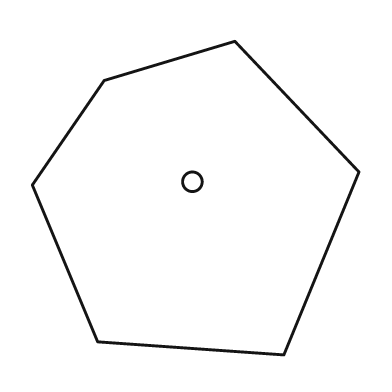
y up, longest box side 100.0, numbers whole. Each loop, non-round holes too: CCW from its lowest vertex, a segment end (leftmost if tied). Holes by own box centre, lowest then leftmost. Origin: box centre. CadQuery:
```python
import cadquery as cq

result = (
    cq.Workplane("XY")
    .moveTo(27.0, -48.0)
    .lineTo(50.0, 8.0)
    .lineTo(12.0, 48.0)
    .lineTo(-28.0, 36.0)
    .lineTo(-50.0, 4.0)
    .lineTo(-30.0, -44.0)
    .close()
    .moveTo(-1.0, 5.0)
    .circle(3.0)
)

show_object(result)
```